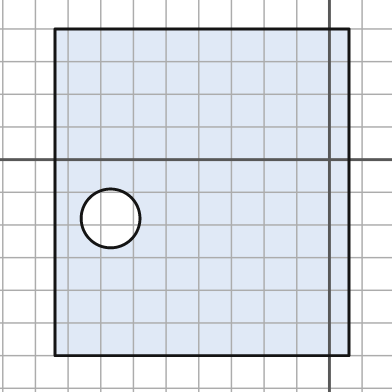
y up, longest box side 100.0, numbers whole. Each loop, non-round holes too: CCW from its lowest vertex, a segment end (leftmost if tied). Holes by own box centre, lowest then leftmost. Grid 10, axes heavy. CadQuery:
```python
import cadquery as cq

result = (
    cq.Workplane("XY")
    .moveTo(-84.0, -60.0)
    .lineTo(6.0, -60.0)
    .lineTo(6.0, 40.0)
    .lineTo(-84.0, 40.0)
    .close()
    .moveTo(-67.0, -18.0)
    .circle(9.0)
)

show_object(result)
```